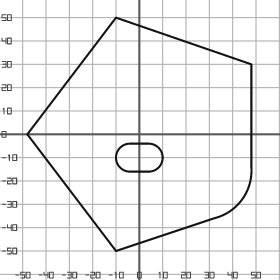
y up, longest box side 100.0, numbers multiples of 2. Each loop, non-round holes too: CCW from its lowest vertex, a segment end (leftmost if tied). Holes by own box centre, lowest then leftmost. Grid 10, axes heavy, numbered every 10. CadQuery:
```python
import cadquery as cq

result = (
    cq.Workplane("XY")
    .moveTo(-10.0, -50.0)
    .lineTo(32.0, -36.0)
    .threePointArc((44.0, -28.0), (48.0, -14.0))
    .lineTo(48.0, 30.0)
    .lineTo(-10.0, 50.0)
    .lineTo(-48.0, 0.0)
    .close()
    .moveTo(-4.0, -16.0)
    .lineTo(4.0, -16.0)
    .threePointArc((10.0, -10.0), (4.0, -4.0))
    .lineTo(-4.0, -4.0)
    .threePointArc((-10.0, -10.0), (-4.0, -16.0))
    .close()
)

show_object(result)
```